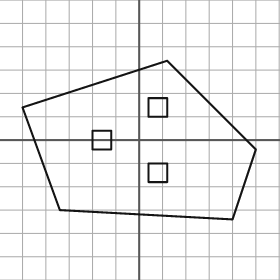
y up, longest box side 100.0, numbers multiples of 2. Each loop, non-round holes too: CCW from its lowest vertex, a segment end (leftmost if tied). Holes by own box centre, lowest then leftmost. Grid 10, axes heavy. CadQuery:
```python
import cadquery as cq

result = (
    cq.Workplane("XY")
    .moveTo(40.0, -34.0)
    .lineTo(50.0, -4.0)
    .lineTo(12.0, 34.0)
    .lineTo(-50.0, 14.0)
    .lineTo(-34.0, -30.0)
    .close()
    .moveTo(4.0, -18.0)
    .lineTo(12.0, -18.0)
    .lineTo(12.0, -10.0)
    .lineTo(4.0, -10.0)
    .close()
    .moveTo(-20.0, -4.0)
    .lineTo(-12.0, -4.0)
    .lineTo(-12.0, 4.0)
    .lineTo(-20.0, 4.0)
    .close()
    .moveTo(4.0, 10.0)
    .lineTo(12.0, 10.0)
    .lineTo(12.0, 18.0)
    .lineTo(4.0, 18.0)
    .close()
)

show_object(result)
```